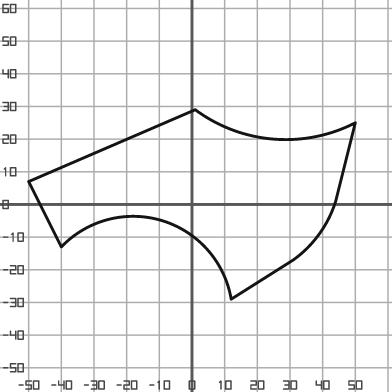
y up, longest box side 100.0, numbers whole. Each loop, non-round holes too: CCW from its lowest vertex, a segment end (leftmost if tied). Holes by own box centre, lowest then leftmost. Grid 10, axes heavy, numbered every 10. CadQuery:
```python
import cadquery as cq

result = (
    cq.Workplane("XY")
    .moveTo(12.0, -29.0)
    .lineTo(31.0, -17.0)
    .threePointArc((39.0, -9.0), (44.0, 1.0))
    .lineTo(50.0, 25.0)
    .threePointArc((25.0, 20.0), (1.0, 29.0))
    .lineTo(-50.0, 7.0)
    .lineTo(-40.0, -13.0)
    .threePointArc((-9.0, -5.0), (12.0, -29.0))
    .close()
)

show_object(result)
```